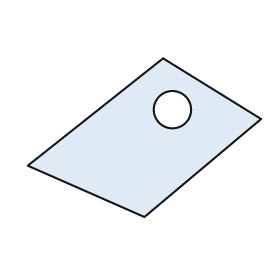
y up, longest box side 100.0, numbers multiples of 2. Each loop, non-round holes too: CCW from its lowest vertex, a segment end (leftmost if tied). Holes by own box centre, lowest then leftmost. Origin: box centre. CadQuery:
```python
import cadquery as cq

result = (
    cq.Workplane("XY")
    .moveTo(0.0, -34.0)
    .lineTo(50.0, 8.0)
    .lineTo(8.0, 34.0)
    .lineTo(-50.0, -12.0)
    .close()
    .moveTo(12.0, 12.0)
    .circle(8.0)
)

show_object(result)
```